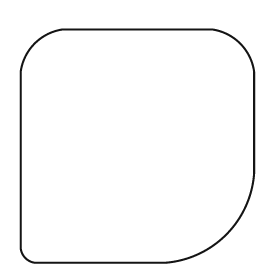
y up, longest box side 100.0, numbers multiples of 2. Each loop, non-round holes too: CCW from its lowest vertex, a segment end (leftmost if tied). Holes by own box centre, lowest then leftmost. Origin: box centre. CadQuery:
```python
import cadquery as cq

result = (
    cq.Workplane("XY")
    .moveTo(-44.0, -50.0)
    .lineTo(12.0, -50.0)
    .threePointArc((38.0, -38.0), (50.0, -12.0))
    .lineTo(50.0, 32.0)
    .threePointArc((44.0, 44.0), (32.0, 50.0))
    .lineTo(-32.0, 50.0)
    .threePointArc((-44.0, 44.0), (-50.0, 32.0))
    .lineTo(-50.0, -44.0)
    .threePointArc((-48.0, -48.0), (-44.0, -50.0))
    .close()
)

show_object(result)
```